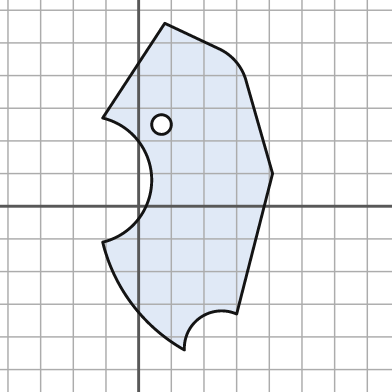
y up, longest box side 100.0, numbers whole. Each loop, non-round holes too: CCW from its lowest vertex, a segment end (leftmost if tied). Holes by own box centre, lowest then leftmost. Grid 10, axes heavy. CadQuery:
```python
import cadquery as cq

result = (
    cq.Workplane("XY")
    .moveTo(14.0, -44.0)
    .threePointArc((19.0, -34.0), (30.0, -33.0))
    .lineTo(41.0, 10.0)
    .lineTo(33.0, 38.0)
    .threePointArc((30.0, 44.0), (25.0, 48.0))
    .lineTo(8.0, 56.0)
    .lineTo(-11.0, 27.0)
    .threePointArc((4.0, 8.0), (-11.0, -11.0))
    .threePointArc((-2.0, -30.0), (14.0, -44.0))
    .close()
    .moveTo(7.0, 25.0)
    .circle(3.0)
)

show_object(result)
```